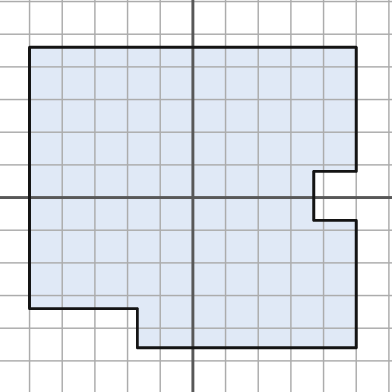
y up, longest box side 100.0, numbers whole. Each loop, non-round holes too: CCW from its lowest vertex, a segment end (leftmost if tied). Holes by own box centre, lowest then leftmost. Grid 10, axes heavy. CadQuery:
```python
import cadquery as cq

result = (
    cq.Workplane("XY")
    .moveTo(-17.0, -46.0)
    .lineTo(50.0, -46.0)
    .lineTo(50.0, -7.0)
    .lineTo(37.0, -7.0)
    .lineTo(37.0, 8.0)
    .lineTo(50.0, 8.0)
    .lineTo(50.0, 46.0)
    .lineTo(-50.0, 46.0)
    .lineTo(-50.0, -34.0)
    .lineTo(-17.0, -34.0)
    .close()
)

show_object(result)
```